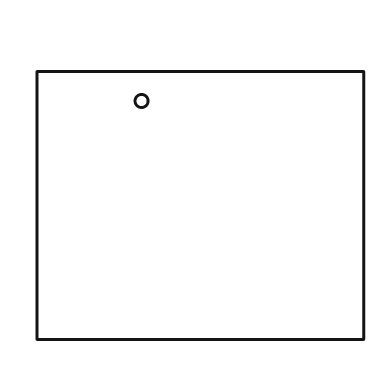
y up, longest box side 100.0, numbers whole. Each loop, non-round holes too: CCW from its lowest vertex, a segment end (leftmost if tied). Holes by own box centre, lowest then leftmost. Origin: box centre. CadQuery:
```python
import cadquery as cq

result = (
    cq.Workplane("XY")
    .moveTo(-50.0, -41.0)
    .lineTo(50.0, -41.0)
    .lineTo(50.0, 41.0)
    .lineTo(-50.0, 41.0)
    .close()
    .moveTo(-18.0, 32.0)
    .circle(2.0)
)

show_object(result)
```